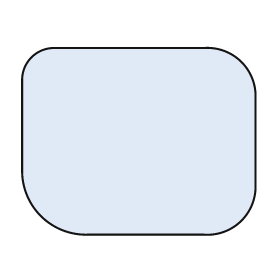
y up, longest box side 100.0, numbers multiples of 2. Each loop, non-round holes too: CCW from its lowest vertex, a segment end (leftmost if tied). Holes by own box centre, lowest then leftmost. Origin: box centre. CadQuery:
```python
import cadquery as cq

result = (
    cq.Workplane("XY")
    .moveTo(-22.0, -40.0)
    .lineTo(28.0, -40.0)
    .threePointArc((44.0, -34.0), (50.0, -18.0))
    .lineTo(50.0, 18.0)
    .threePointArc((44.0, 34.0), (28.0, 40.0))
    .lineTo(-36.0, 40.0)
    .threePointArc((-46.0, 36.0), (-50.0, 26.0))
    .lineTo(-50.0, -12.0)
    .threePointArc((-42.0, -32.0), (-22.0, -40.0))
    .close()
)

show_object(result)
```